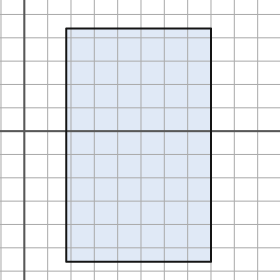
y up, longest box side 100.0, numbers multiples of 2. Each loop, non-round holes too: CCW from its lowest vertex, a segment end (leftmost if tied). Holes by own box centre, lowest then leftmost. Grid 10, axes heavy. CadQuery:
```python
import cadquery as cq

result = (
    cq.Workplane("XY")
    .moveTo(18.0, -56.0)
    .lineTo(80.0, -56.0)
    .lineTo(80.0, 44.0)
    .lineTo(18.0, 44.0)
    .close()
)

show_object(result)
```